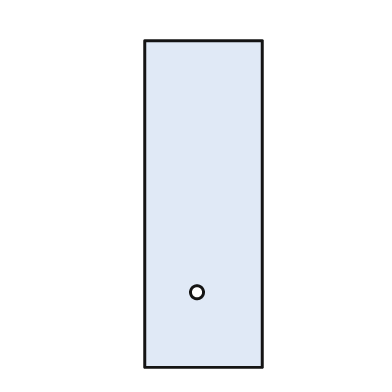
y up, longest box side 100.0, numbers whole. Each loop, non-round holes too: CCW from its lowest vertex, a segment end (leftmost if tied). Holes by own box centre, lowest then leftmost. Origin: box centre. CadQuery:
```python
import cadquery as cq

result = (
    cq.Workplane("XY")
    .moveTo(-18.0, -50.0)
    .lineTo(18.0, -50.0)
    .lineTo(18.0, 50.0)
    .lineTo(-18.0, 50.0)
    .close()
    .moveTo(-2.0, -27.0)
    .circle(2.0)
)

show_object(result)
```